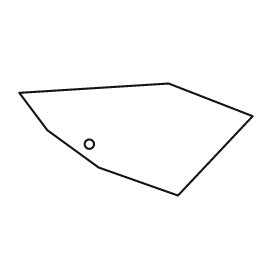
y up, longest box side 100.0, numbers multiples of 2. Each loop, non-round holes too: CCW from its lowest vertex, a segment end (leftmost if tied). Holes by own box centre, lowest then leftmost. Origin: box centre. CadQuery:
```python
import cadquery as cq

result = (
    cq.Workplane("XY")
    .moveTo(18.0, -24.0)
    .lineTo(50.0, 10.0)
    .lineTo(14.0, 24.0)
    .lineTo(-50.0, 20.0)
    .lineTo(-38.0, 4.0)
    .lineTo(-16.0, -12.0)
    .close()
    .moveTo(-20.0, -2.0)
    .circle(2.0)
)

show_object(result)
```